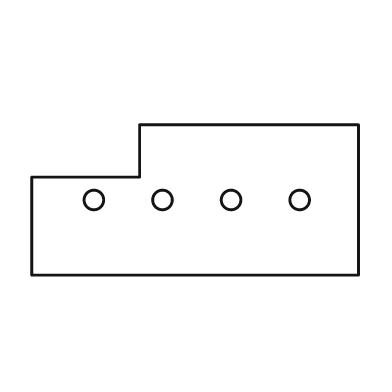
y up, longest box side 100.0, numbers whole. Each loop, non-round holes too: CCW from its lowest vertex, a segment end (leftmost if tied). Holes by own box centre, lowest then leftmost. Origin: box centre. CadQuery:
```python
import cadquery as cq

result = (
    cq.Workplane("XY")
    .moveTo(-50.0, -23.0)
    .lineTo(50.0, -23.0)
    .lineTo(50.0, 23.0)
    .lineTo(-17.0, 23.0)
    .lineTo(-17.0, 7.0)
    .lineTo(-50.0, 7.0)
    .close()
    .moveTo(-31.0, 0.0)
    .circle(3.0)
    .moveTo(-10.0, 0.0)
    .circle(3.0)
    .moveTo(11.0, 0.0)
    .circle(3.0)
    .moveTo(32.0, 0.0)
    .circle(3.0)
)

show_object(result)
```